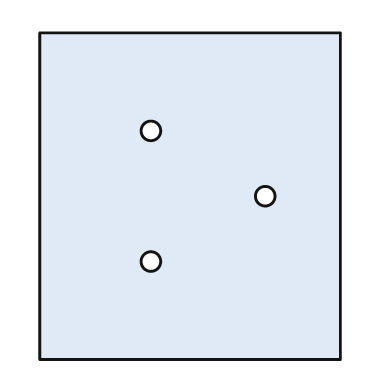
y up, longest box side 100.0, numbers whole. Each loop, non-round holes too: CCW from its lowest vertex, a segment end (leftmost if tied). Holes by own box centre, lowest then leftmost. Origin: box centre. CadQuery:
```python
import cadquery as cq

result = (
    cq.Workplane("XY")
    .moveTo(-46.0, -50.0)
    .lineTo(46.0, -50.0)
    .lineTo(46.0, 50.0)
    .lineTo(-46.0, 50.0)
    .close()
    .moveTo(-12.0, -20.0)
    .circle(3.0)
    .moveTo(23.0, 0.0)
    .circle(3.0)
    .moveTo(-12.0, 20.0)
    .circle(3.0)
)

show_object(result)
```